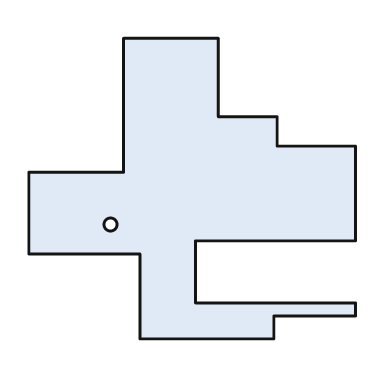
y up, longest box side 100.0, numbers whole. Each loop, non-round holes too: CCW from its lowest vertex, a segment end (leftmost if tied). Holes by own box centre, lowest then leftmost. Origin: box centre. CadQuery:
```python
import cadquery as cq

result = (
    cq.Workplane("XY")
    .moveTo(-16.0, -46.0)
    .lineTo(25.0, -46.0)
    .lineTo(25.0, -39.0)
    .lineTo(50.0, -39.0)
    .lineTo(50.0, -35.0)
    .lineTo(1.0, -35.0)
    .lineTo(1.0, -16.0)
    .lineTo(50.0, -16.0)
    .lineTo(50.0, 13.0)
    .lineTo(26.0, 13.0)
    .lineTo(26.0, 22.0)
    .lineTo(8.0, 22.0)
    .lineTo(8.0, 46.0)
    .lineTo(-21.0, 46.0)
    .lineTo(-21.0, 5.0)
    .lineTo(-50.0, 5.0)
    .lineTo(-50.0, -20.0)
    .lineTo(-16.0, -20.0)
    .close()
    .moveTo(-25.0, -11.0)
    .circle(2.0)
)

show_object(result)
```